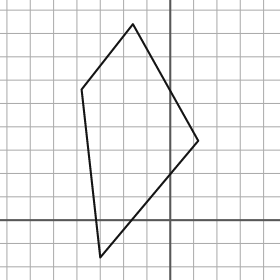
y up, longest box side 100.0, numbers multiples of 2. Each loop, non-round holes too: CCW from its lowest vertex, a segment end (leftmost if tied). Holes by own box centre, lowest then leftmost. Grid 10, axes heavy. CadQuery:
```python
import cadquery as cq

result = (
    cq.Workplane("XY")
    .moveTo(-30.0, -16.0)
    .lineTo(12.0, 34.0)
    .lineTo(-16.0, 84.0)
    .lineTo(-38.0, 56.0)
    .close()
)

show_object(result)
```